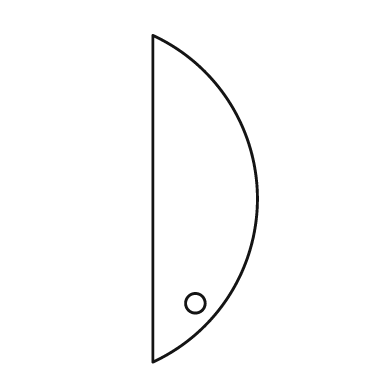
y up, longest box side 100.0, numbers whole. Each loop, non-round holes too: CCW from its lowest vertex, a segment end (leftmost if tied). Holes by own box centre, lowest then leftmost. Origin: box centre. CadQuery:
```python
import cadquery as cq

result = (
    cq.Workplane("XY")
    .moveTo(-16.0, -50.0)
    .threePointArc((16.0, 0.0), (-16.0, 50.0))
    .close()
    .moveTo(-3.0, -32.0)
    .circle(3.0)
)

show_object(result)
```